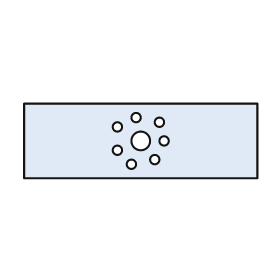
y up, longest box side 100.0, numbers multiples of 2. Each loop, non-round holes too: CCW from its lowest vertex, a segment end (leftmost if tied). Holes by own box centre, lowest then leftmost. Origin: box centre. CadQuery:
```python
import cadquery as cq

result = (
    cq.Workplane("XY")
    .moveTo(-50.0, -16.0)
    .lineTo(50.0, -16.0)
    .lineTo(50.0, 16.0)
    .lineTo(-50.0, 16.0)
    .close()
    .moveTo(-4.0, -10.0)
    .circle(2.0)
    .moveTo(6.0, -8.0)
    .circle(2.0)
    .moveTo(-10.0, -4.0)
    .circle(2.0)
    .moveTo(0.0, 0.0)
    .circle(4.0)
    .moveTo(10.0, 0.0)
    .circle(2.0)
    .moveTo(-10.0, 6.0)
    .circle(2.0)
    .moveTo(8.0, 8.0)
    .circle(2.0)
    .moveTo(-2.0, 10.0)
    .circle(2.0)
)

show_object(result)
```